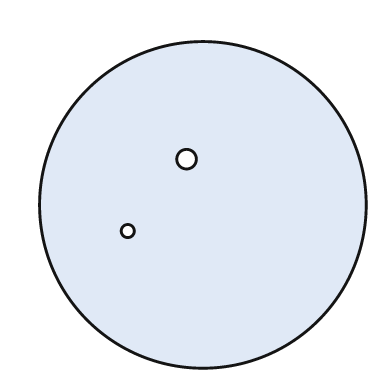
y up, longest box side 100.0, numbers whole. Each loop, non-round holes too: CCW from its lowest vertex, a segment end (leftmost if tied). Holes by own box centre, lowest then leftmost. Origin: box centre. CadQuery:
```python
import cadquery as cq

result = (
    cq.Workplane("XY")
    .moveTo(0.0, 0.0)
    .circle(50.0)
    .moveTo(-23.0, -8.0)
    .circle(2.0)
    .moveTo(-5.0, 14.0)
    .circle(3.0)
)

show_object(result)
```